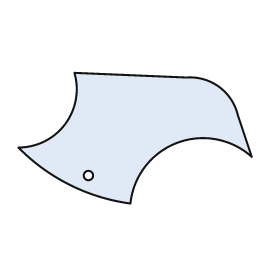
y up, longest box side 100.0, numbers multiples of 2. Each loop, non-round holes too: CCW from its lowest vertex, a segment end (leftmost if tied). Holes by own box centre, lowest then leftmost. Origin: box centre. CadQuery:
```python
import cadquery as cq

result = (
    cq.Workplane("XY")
    .moveTo(-2.0, -28.0)
    .threePointArc((18.0, -2.0), (50.0, -8.0))
    .lineTo(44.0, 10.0)
    .threePointArc((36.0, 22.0), (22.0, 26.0))
    .lineTo(-26.0, 28.0)
    .threePointArc((-30.0, 6.0), (-50.0, -4.0))
    .threePointArc((-28.0, -20.0), (-2.0, -28.0))
    .close()
    .moveTo(-20.0, -16.0)
    .circle(2.0)
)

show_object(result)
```